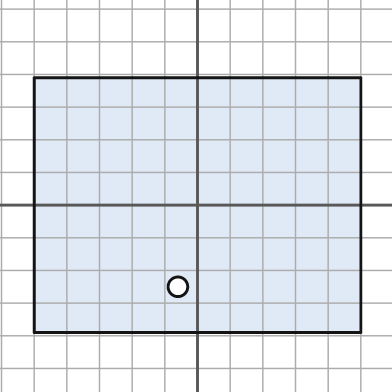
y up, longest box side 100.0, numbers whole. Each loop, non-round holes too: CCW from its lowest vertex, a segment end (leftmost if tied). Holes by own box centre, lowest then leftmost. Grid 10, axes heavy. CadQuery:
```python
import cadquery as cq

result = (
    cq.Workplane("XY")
    .moveTo(-50.0, -39.0)
    .lineTo(50.0, -39.0)
    .lineTo(50.0, 39.0)
    .lineTo(-50.0, 39.0)
    .close()
    .moveTo(-6.0, -25.0)
    .circle(3.0)
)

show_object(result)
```